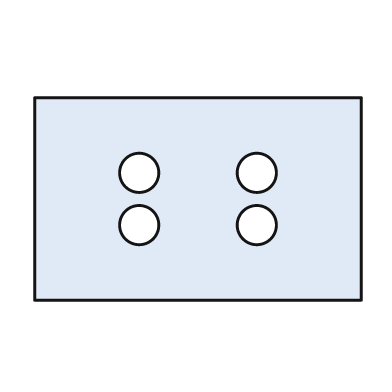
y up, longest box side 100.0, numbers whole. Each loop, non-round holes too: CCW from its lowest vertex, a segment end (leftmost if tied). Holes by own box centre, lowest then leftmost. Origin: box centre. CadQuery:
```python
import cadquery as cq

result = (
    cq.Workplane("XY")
    .moveTo(-50.0, -31.0)
    .lineTo(50.0, -31.0)
    .lineTo(50.0, 31.0)
    .lineTo(-50.0, 31.0)
    .close()
    .moveTo(-18.0, -8.0)
    .circle(6.0)
    .moveTo(18.0, -8.0)
    .circle(6.0)
    .moveTo(-18.0, 8.0)
    .circle(6.0)
    .moveTo(18.0, 8.0)
    .circle(6.0)
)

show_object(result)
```